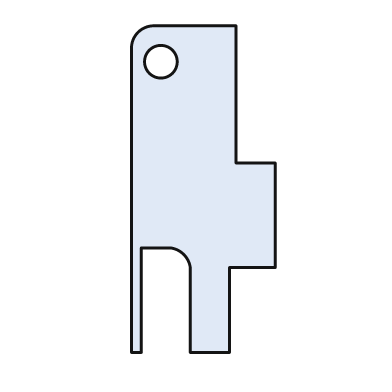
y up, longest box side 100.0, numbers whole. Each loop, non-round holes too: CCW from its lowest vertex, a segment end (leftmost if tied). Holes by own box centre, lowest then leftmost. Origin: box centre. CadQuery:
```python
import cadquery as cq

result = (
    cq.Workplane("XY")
    .moveTo(-22.0, -50.0)
    .lineTo(-19.0, -50.0)
    .lineTo(-19.0, -18.0)
    .lineTo(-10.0, -18.0)
    .threePointArc((-6.0, -20.0), (-4.0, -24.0))
    .lineTo(-4.0, -50.0)
    .lineTo(8.0, -50.0)
    .lineTo(8.0, -24.0)
    .lineTo(22.0, -24.0)
    .lineTo(22.0, 8.0)
    .lineTo(10.0, 8.0)
    .lineTo(10.0, 50.0)
    .lineTo(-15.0, 50.0)
    .threePointArc((-20.0, 48.0), (-22.0, 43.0))
    .close()
    .moveTo(-13.0, 39.0)
    .circle(5.0)
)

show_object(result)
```